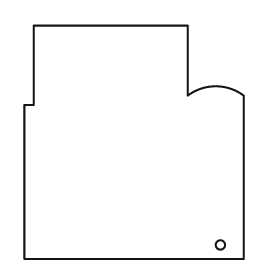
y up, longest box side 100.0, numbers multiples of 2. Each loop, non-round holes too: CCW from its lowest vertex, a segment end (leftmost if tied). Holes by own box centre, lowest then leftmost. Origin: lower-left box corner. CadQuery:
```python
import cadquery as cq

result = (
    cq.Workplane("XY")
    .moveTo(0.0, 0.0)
    .lineTo(94.0, 0.0)
    .lineTo(94.0, 70.0)
    .threePointArc((82.0, 74.0), (70.0, 70.0))
    .lineTo(70.0, 100.0)
    .lineTo(4.0, 100.0)
    .lineTo(4.0, 66.0)
    .lineTo(0.0, 66.0)
    .close()
    .moveTo(84.0, 6.0)
    .circle(2.0)
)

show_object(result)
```